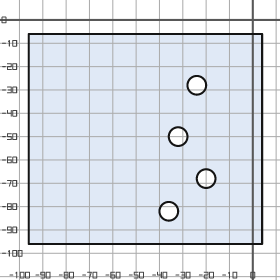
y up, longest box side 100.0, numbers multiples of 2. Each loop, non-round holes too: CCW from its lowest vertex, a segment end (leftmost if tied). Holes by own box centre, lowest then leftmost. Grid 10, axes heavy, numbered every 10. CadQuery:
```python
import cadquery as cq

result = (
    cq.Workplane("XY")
    .moveTo(-96.0, -96.0)
    .lineTo(4.0, -96.0)
    .lineTo(4.0, -6.0)
    .lineTo(-96.0, -6.0)
    .close()
    .moveTo(-36.0, -82.0)
    .circle(4.0)
    .moveTo(-20.0, -68.0)
    .circle(4.0)
    .moveTo(-32.0, -50.0)
    .circle(4.0)
    .moveTo(-24.0, -28.0)
    .circle(4.0)
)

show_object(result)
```